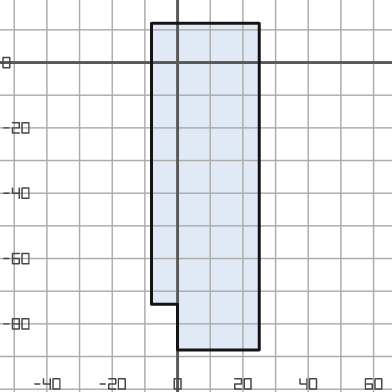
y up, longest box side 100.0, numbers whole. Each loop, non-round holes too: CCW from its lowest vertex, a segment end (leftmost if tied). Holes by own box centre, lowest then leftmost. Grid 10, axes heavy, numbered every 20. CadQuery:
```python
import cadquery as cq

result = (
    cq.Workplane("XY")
    .moveTo(0.0, -88.0)
    .lineTo(25.0, -88.0)
    .lineTo(25.0, 12.0)
    .lineTo(-8.0, 12.0)
    .lineTo(-8.0, -74.0)
    .lineTo(0.0, -74.0)
    .close()
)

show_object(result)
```